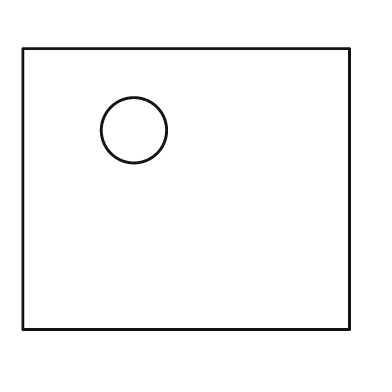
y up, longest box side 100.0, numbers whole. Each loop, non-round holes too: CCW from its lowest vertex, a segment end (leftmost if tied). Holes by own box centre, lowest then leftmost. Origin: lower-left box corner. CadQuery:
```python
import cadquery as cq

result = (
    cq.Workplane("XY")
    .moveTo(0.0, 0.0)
    .lineTo(100.0, 0.0)
    .lineTo(100.0, 86.0)
    .lineTo(0.0, 86.0)
    .close()
    .moveTo(34.0, 61.0)
    .circle(10.0)
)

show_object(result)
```